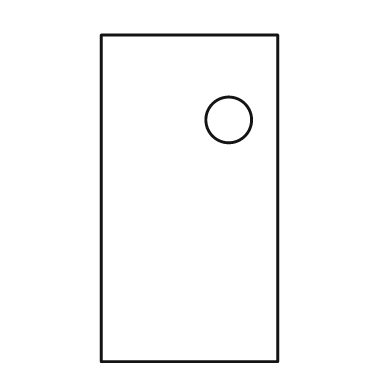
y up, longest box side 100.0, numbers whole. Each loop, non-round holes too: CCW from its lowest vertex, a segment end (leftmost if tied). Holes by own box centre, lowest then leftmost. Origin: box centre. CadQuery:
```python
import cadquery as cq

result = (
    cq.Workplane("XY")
    .moveTo(-27.0, -50.0)
    .lineTo(27.0, -50.0)
    .lineTo(27.0, 50.0)
    .lineTo(-27.0, 50.0)
    .close()
    .moveTo(12.0, 24.0)
    .circle(7.0)
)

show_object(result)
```